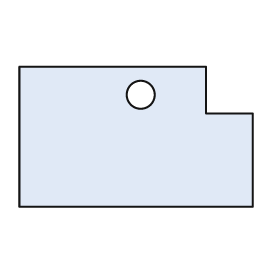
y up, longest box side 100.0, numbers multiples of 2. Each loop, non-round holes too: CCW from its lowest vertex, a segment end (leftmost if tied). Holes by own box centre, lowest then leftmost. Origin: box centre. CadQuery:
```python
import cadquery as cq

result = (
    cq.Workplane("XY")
    .moveTo(-50.0, -30.0)
    .lineTo(50.0, -30.0)
    .lineTo(50.0, 10.0)
    .lineTo(30.0, 10.0)
    .lineTo(30.0, 30.0)
    .lineTo(-50.0, 30.0)
    .close()
    .moveTo(2.0, 18.0)
    .circle(6.0)
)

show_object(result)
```